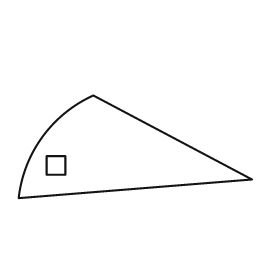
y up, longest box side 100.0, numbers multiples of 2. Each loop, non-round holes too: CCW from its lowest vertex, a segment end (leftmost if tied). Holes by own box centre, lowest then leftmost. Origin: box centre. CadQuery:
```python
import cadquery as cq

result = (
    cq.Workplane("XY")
    .moveTo(-50.0, -22.0)
    .lineTo(50.0, -14.0)
    .lineTo(-18.0, 22.0)
    .threePointArc((-40.0, 4.0), (-50.0, -22.0))
    .close()
    .moveTo(-38.0, -12.0)
    .lineTo(-30.0, -12.0)
    .lineTo(-30.0, -4.0)
    .lineTo(-38.0, -4.0)
    .close()
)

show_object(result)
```